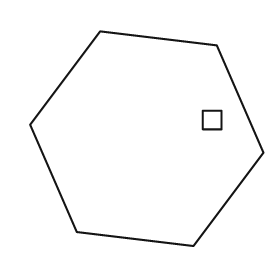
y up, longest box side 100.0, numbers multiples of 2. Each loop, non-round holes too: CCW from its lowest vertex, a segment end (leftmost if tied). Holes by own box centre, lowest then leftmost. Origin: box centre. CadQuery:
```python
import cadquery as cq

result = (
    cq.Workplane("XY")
    .moveTo(20.0, -46.0)
    .lineTo(50.0, -6.0)
    .lineTo(30.0, 40.0)
    .lineTo(-20.0, 46.0)
    .lineTo(-50.0, 6.0)
    .lineTo(-30.0, -40.0)
    .close()
    .moveTo(24.0, 4.0)
    .lineTo(32.0, 4.0)
    .lineTo(32.0, 12.0)
    .lineTo(24.0, 12.0)
    .close()
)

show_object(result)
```